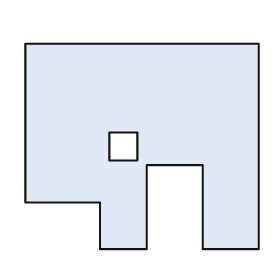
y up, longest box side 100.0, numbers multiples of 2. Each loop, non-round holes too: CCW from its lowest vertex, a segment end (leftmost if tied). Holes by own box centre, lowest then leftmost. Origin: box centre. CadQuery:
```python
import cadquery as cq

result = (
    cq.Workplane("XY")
    .moveTo(-18.0, -44.0)
    .lineTo(2.0, -44.0)
    .lineTo(2.0, -8.0)
    .lineTo(26.0, -8.0)
    .lineTo(26.0, -44.0)
    .lineTo(50.0, -44.0)
    .lineTo(50.0, 44.0)
    .lineTo(-50.0, 44.0)
    .lineTo(-50.0, -24.0)
    .lineTo(-18.0, -24.0)
    .close()
    .moveTo(-14.0, -6.0)
    .lineTo(-2.0, -6.0)
    .lineTo(-2.0, 6.0)
    .lineTo(-14.0, 6.0)
    .close()
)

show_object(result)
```